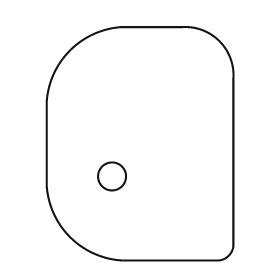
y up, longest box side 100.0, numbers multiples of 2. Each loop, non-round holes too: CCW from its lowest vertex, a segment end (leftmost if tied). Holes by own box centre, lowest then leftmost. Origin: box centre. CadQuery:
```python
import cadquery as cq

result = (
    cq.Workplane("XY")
    .moveTo(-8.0, -50.0)
    .lineTo(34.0, -50.0)
    .threePointArc((38.0, -48.0), (40.0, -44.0))
    .lineTo(40.0, 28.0)
    .threePointArc((34.0, 44.0), (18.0, 50.0))
    .lineTo(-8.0, 50.0)
    .threePointArc((-30.0, 40.0), (-40.0, 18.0))
    .lineTo(-40.0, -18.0)
    .threePointArc((-30.0, -40.0), (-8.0, -50.0))
    .close()
    .moveTo(-12.0, -14.0)
    .circle(6.0)
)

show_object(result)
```